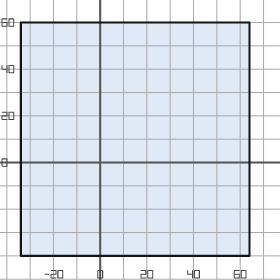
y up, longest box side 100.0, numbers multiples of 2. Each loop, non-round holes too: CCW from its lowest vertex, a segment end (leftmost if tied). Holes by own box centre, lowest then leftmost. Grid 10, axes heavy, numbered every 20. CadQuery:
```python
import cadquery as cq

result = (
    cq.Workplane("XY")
    .moveTo(-34.0, -40.0)
    .lineTo(64.0, -40.0)
    .lineTo(64.0, 60.0)
    .lineTo(-34.0, 60.0)
    .close()
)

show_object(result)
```